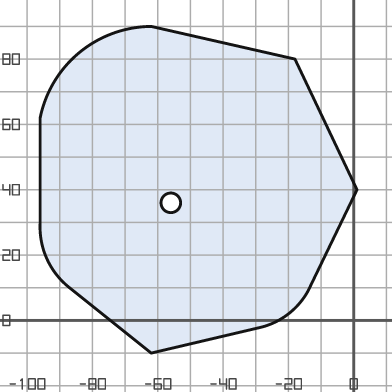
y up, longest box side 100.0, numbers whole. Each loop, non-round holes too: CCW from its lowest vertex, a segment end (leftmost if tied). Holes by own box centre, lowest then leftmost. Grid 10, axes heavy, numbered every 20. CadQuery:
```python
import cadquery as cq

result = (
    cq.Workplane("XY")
    .moveTo(-62.0, -10.0)
    .lineTo(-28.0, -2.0)
    .threePointArc((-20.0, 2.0), (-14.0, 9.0))
    .lineTo(1.0, 40.0)
    .lineTo(-18.0, 80.0)
    .lineTo(-62.0, 90.0)
    .threePointArc((-84.0, 82.0), (-96.0, 62.0))
    .lineTo(-96.0, 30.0)
    .threePointArc((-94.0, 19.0), (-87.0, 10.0))
    .close()
    .moveTo(-56.0, 36.0)
    .circle(3.0)
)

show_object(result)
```